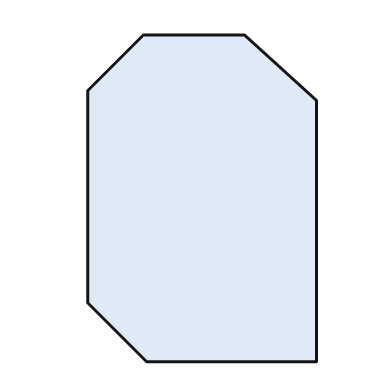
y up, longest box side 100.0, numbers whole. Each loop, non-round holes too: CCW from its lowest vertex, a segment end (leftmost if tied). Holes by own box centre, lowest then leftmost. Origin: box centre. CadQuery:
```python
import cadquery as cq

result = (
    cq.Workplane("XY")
    .moveTo(-17.0, -50.0)
    .lineTo(35.0, -50.0)
    .lineTo(35.0, 30.0)
    .lineTo(13.0, 50.0)
    .lineTo(-18.0, 50.0)
    .lineTo(-35.0, 33.0)
    .lineTo(-35.0, -32.0)
    .close()
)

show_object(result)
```